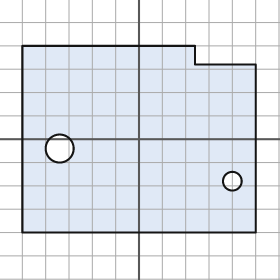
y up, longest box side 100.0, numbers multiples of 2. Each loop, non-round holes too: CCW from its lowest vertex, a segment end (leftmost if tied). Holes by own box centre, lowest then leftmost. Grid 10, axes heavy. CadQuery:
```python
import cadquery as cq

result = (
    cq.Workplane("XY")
    .moveTo(-50.0, -40.0)
    .lineTo(50.0, -40.0)
    .lineTo(50.0, 32.0)
    .lineTo(24.0, 32.0)
    .lineTo(24.0, 40.0)
    .lineTo(-50.0, 40.0)
    .close()
    .moveTo(40.0, -18.0)
    .circle(4.0)
    .moveTo(-34.0, -4.0)
    .circle(6.0)
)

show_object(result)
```